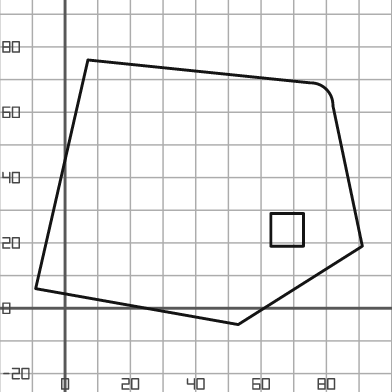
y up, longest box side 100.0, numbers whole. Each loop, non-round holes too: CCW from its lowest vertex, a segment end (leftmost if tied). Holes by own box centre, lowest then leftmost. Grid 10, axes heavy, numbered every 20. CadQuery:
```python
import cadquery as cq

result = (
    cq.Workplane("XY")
    .moveTo(53.0, -5.0)
    .lineTo(91.0, 19.0)
    .lineTo(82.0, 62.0)
    .threePointArc((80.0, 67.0), (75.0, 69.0))
    .lineTo(7.0, 76.0)
    .lineTo(-9.0, 6.0)
    .close()
    .moveTo(63.0, 19.0)
    .lineTo(73.0, 19.0)
    .lineTo(73.0, 29.0)
    .lineTo(63.0, 29.0)
    .close()
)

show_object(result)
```